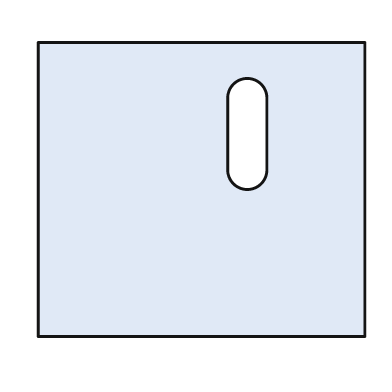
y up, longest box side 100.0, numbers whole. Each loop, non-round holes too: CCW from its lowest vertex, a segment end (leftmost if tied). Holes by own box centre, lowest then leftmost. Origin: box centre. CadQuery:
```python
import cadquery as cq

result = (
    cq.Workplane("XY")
    .moveTo(-50.0, -45.0)
    .lineTo(50.0, -45.0)
    .lineTo(50.0, 45.0)
    .lineTo(-50.0, 45.0)
    .close()
    .moveTo(8.0, 6.0)
    .threePointArc((14.0, 0.0), (20.0, 6.0))
    .lineTo(20.0, 28.0)
    .threePointArc((14.0, 34.0), (8.0, 28.0))
    .close()
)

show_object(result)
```